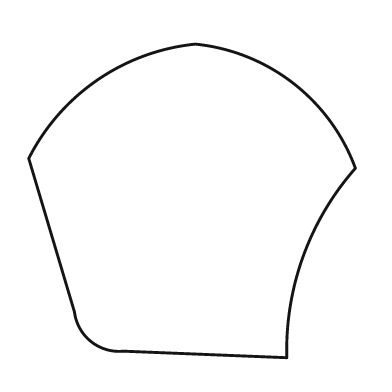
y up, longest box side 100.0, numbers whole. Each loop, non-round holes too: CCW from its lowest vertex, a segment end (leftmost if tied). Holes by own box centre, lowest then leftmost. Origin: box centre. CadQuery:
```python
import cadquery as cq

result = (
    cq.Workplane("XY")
    .moveTo(29.0, -48.0)
    .threePointArc((34.0, -17.0), (50.0, 10.0))
    .threePointArc((31.0, 36.0), (1.0, 48.0))
    .threePointArc((-29.0, 37.0), (-50.0, 13.0))
    .lineTo(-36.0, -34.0)
    .threePointArc((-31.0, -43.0), (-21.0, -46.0))
    .close()
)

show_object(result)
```